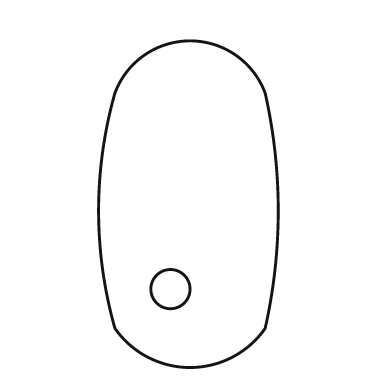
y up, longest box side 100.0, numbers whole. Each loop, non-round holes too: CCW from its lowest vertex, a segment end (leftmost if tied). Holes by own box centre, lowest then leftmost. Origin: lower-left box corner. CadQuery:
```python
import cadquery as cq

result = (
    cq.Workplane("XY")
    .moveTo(5.0, 12.0)
    .threePointArc((28.0, 0.0), (51.0, 12.0))
    .threePointArc((55.0, 48.0), (51.0, 84.0))
    .threePointArc((28.0, 100.0), (5.0, 84.0))
    .threePointArc((0.0, 48.0), (5.0, 12.0))
    .close()
    .moveTo(22.0, 24.0)
    .circle(6.0)
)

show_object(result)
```